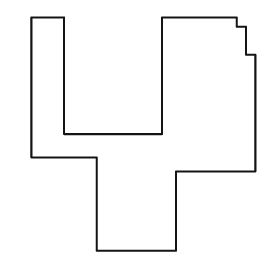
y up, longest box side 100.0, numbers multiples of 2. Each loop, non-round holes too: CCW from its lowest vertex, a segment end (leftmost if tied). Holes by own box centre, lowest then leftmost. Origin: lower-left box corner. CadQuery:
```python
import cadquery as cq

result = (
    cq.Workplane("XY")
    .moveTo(28.0, 0.0)
    .lineTo(62.0, 0.0)
    .lineTo(62.0, 34.0)
    .lineTo(96.0, 34.0)
    .lineTo(96.0, 84.0)
    .lineTo(92.0, 84.0)
    .lineTo(92.0, 96.0)
    .lineTo(88.0, 96.0)
    .lineTo(88.0, 100.0)
    .lineTo(56.0, 100.0)
    .lineTo(56.0, 50.0)
    .lineTo(14.0, 50.0)
    .lineTo(14.0, 100.0)
    .lineTo(0.0, 100.0)
    .lineTo(0.0, 40.0)
    .lineTo(28.0, 40.0)
    .close()
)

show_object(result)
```